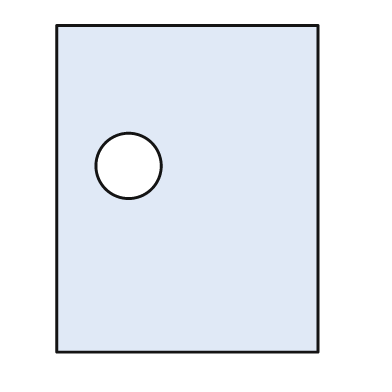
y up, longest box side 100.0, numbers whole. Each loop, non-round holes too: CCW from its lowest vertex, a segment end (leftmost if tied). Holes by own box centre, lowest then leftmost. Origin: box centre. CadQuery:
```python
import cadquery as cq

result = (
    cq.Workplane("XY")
    .moveTo(-40.0, -50.0)
    .lineTo(40.0, -50.0)
    .lineTo(40.0, 50.0)
    .lineTo(-40.0, 50.0)
    .close()
    .moveTo(-18.0, 7.0)
    .circle(10.0)
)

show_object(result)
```